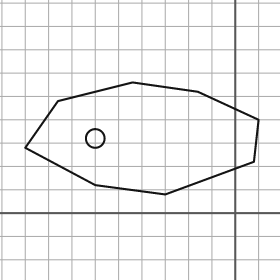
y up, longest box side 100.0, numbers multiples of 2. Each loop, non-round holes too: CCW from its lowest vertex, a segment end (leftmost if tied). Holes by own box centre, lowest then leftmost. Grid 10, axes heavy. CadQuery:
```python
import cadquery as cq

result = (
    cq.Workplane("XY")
    .moveTo(-30.0, 8.0)
    .lineTo(8.0, 22.0)
    .lineTo(10.0, 40.0)
    .lineTo(-16.0, 52.0)
    .lineTo(-44.0, 56.0)
    .lineTo(-76.0, 48.0)
    .lineTo(-90.0, 28.0)
    .lineTo(-60.0, 12.0)
    .close()
    .moveTo(-60.0, 32.0)
    .circle(4.0)
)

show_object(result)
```